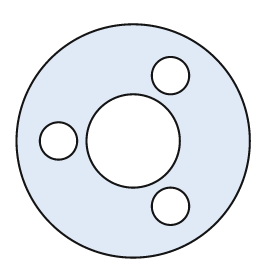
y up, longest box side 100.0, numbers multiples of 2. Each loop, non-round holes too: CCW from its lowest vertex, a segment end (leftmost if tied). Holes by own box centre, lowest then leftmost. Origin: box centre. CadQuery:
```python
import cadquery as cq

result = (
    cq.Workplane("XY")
    .moveTo(0.0, 0.0)
    .circle(50.0)
    .moveTo(16.0, -28.0)
    .circle(8.0)
    .moveTo(-32.0, 0.0)
    .circle(8.0)
    .moveTo(0.0, 0.0)
    .circle(20.0)
    .moveTo(16.0, 28.0)
    .circle(8.0)
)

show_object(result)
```